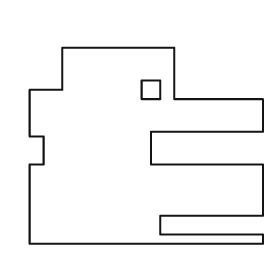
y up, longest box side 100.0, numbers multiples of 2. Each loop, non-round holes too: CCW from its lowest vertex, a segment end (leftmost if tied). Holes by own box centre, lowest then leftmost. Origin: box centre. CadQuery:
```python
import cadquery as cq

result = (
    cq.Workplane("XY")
    .moveTo(-50.0, -42.0)
    .lineTo(50.0, -42.0)
    .lineTo(50.0, -38.0)
    .lineTo(6.0, -38.0)
    .lineTo(6.0, -30.0)
    .lineTo(50.0, -30.0)
    .lineTo(50.0, -8.0)
    .lineTo(2.0, -8.0)
    .lineTo(2.0, 6.0)
    .lineTo(50.0, 6.0)
    .lineTo(50.0, 20.0)
    .lineTo(12.0, 20.0)
    .lineTo(12.0, 42.0)
    .lineTo(-36.0, 42.0)
    .lineTo(-36.0, 24.0)
    .lineTo(-50.0, 24.0)
    .lineTo(-50.0, 4.0)
    .lineTo(-44.0, 4.0)
    .lineTo(-44.0, -8.0)
    .lineTo(-50.0, -8.0)
    .close()
    .moveTo(-2.0, 20.0)
    .lineTo(6.0, 20.0)
    .lineTo(6.0, 28.0)
    .lineTo(-2.0, 28.0)
    .close()
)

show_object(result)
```